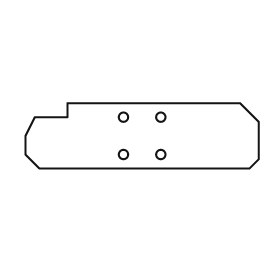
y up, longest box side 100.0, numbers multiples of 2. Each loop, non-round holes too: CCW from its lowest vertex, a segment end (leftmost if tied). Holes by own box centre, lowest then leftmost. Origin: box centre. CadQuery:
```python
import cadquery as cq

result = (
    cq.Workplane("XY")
    .moveTo(-44.0, -14.0)
    .lineTo(46.0, -14.0)
    .lineTo(50.0, -10.0)
    .lineTo(50.0, 6.0)
    .lineTo(42.0, 14.0)
    .lineTo(-32.0, 14.0)
    .lineTo(-32.0, 8.0)
    .lineTo(-46.0, 8.0)
    .lineTo(-50.0, 0.0)
    .lineTo(-50.0, -8.0)
    .close()
    .moveTo(-8.0, -8.0)
    .circle(2.0)
    .moveTo(8.0, -8.0)
    .circle(2.0)
    .moveTo(-8.0, 8.0)
    .circle(2.0)
    .moveTo(8.0, 8.0)
    .circle(2.0)
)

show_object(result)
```